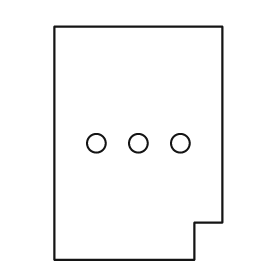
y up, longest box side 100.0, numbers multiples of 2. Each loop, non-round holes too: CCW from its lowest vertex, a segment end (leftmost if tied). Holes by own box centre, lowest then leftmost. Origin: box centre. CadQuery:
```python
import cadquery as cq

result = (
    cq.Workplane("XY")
    .moveTo(-36.0, -50.0)
    .lineTo(24.0, -50.0)
    .lineTo(24.0, -34.0)
    .lineTo(36.0, -34.0)
    .lineTo(36.0, 50.0)
    .lineTo(-36.0, 50.0)
    .close()
    .moveTo(-18.0, 0.0)
    .circle(4.0)
    .moveTo(0.0, 0.0)
    .circle(4.0)
    .moveTo(18.0, 0.0)
    .circle(4.0)
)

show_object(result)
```